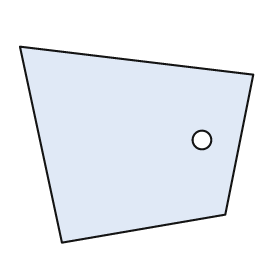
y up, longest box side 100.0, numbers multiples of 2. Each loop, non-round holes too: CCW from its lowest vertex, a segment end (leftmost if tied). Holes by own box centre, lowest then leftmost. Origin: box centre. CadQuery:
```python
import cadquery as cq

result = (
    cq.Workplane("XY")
    .moveTo(-32.0, -42.0)
    .lineTo(38.0, -30.0)
    .lineTo(50.0, 30.0)
    .lineTo(-50.0, 42.0)
    .close()
    .moveTo(28.0, 2.0)
    .circle(4.0)
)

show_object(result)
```